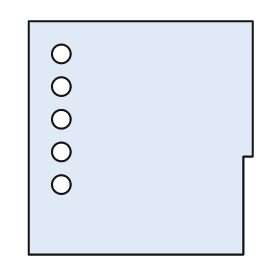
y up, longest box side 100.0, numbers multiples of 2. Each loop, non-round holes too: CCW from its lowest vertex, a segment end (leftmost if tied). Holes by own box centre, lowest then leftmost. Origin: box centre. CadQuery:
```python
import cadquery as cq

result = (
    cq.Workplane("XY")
    .moveTo(-48.0, -50.0)
    .lineTo(44.0, -50.0)
    .lineTo(44.0, -8.0)
    .lineTo(48.0, -8.0)
    .lineTo(48.0, 50.0)
    .lineTo(-48.0, 50.0)
    .close()
    .moveTo(-34.0, -20.0)
    .circle(4.0)
    .moveTo(-34.0, -6.0)
    .circle(4.0)
    .moveTo(-34.0, 8.0)
    .circle(4.0)
    .moveTo(-34.0, 22.0)
    .circle(4.0)
    .moveTo(-34.0, 36.0)
    .circle(4.0)
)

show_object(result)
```